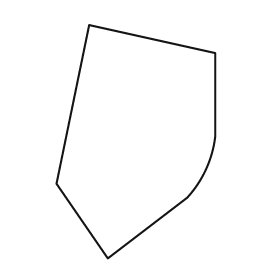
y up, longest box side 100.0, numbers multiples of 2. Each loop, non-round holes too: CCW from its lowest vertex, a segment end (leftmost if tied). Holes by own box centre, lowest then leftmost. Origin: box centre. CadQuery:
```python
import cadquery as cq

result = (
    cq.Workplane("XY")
    .moveTo(-12.0, -50.0)
    .lineTo(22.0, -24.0)
    .threePointArc((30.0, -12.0), (34.0, 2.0))
    .lineTo(34.0, 38.0)
    .lineTo(-20.0, 50.0)
    .lineTo(-34.0, -18.0)
    .close()
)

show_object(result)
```